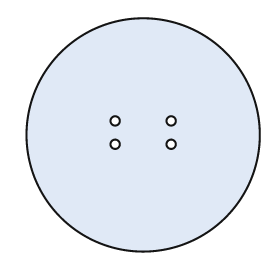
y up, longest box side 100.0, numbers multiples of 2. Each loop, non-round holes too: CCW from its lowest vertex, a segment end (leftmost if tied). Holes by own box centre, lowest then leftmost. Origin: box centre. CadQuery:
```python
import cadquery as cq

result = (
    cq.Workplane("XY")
    .moveTo(0.0, 0.0)
    .circle(50.0)
    .moveTo(-12.0, -4.0)
    .circle(2.0)
    .moveTo(12.0, -4.0)
    .circle(2.0)
    .moveTo(-12.0, 6.0)
    .circle(2.0)
    .moveTo(12.0, 6.0)
    .circle(2.0)
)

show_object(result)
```